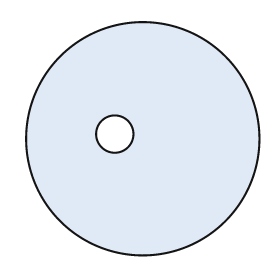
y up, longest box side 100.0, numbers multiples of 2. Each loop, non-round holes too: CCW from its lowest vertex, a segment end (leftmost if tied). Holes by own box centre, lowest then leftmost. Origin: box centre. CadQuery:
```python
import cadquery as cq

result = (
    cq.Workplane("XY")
    .moveTo(0.0, 0.0)
    .circle(50.0)
    .moveTo(-12.0, 2.0)
    .circle(8.0)
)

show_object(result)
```